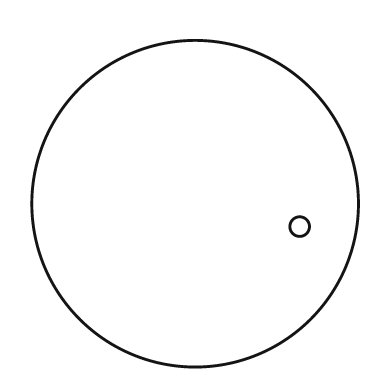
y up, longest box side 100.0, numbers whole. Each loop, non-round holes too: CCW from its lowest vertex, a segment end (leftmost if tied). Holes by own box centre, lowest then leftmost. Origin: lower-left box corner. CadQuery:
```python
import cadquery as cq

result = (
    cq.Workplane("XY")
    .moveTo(50.0, 50.0)
    .circle(50.0)
    .moveTo(82.0, 43.0)
    .circle(3.0)
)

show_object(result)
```